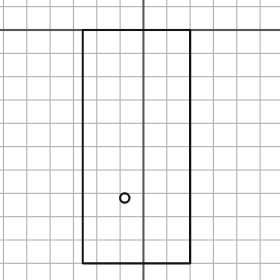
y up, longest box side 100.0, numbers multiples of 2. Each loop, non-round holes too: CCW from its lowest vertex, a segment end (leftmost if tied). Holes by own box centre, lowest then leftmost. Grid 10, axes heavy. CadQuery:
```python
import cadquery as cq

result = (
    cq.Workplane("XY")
    .moveTo(-26.0, -100.0)
    .lineTo(20.0, -100.0)
    .lineTo(20.0, 0.0)
    .lineTo(-26.0, 0.0)
    .close()
    .moveTo(-8.0, -72.0)
    .circle(2.0)
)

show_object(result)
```